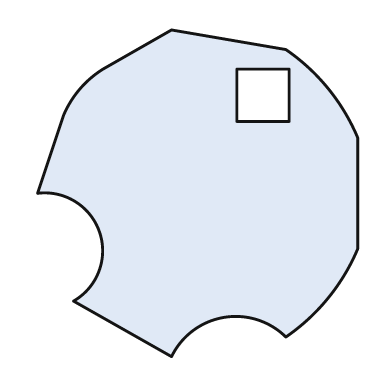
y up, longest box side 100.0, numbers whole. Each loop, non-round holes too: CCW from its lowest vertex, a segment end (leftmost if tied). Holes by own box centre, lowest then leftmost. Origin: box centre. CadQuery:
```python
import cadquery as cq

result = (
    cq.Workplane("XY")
    .moveTo(-8.0, -50.0)
    .threePointArc((8.0, -38.0), (27.0, -44.0))
    .threePointArc((40.0, -32.0), (49.0, -17.0))
    .lineTo(49.0, 17.0)
    .threePointArc((40.0, 32.0), (27.0, 44.0))
    .lineTo(-8.0, 50.0)
    .lineTo(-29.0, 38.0)
    .threePointArc((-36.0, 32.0), (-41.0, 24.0))
    .lineTo(-49.0, 0.0)
    .threePointArc((-30.0, -12.0), (-38.0, -33.0))
    .close()
    .moveTo(12.0, 22.0)
    .lineTo(28.0, 22.0)
    .lineTo(28.0, 38.0)
    .lineTo(12.0, 38.0)
    .close()
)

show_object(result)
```